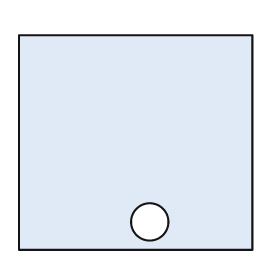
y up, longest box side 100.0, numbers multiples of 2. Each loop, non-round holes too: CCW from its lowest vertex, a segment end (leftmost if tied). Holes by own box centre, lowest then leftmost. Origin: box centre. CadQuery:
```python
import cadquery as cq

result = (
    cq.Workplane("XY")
    .moveTo(-50.0, -46.0)
    .lineTo(50.0, -46.0)
    .lineTo(50.0, 46.0)
    .lineTo(-50.0, 46.0)
    .close()
    .moveTo(6.0, -34.0)
    .circle(8.0)
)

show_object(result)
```